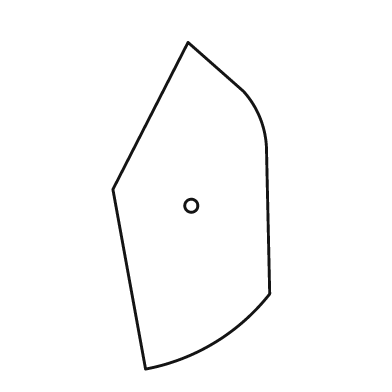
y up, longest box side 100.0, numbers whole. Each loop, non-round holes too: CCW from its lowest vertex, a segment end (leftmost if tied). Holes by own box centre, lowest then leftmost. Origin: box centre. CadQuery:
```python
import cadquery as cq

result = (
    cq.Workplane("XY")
    .moveTo(-14.0, -50.0)
    .threePointArc((7.0, -42.0), (24.0, -27.0))
    .lineTo(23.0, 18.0)
    .threePointArc((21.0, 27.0), (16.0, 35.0))
    .lineTo(-1.0, 50.0)
    .lineTo(-24.0, 5.0)
    .close()
    .moveTo(0.0, 0.0)
    .circle(2.0)
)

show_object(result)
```